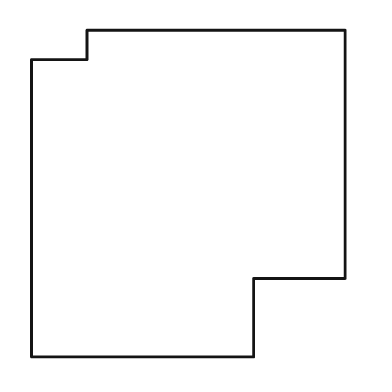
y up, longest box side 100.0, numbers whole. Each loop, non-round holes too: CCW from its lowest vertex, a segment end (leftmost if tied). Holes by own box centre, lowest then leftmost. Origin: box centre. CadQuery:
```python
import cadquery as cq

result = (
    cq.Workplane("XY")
    .moveTo(-48.0, -50.0)
    .lineTo(20.0, -50.0)
    .lineTo(20.0, -26.0)
    .lineTo(48.0, -26.0)
    .lineTo(48.0, 50.0)
    .lineTo(-31.0, 50.0)
    .lineTo(-31.0, 41.0)
    .lineTo(-48.0, 41.0)
    .close()
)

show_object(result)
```